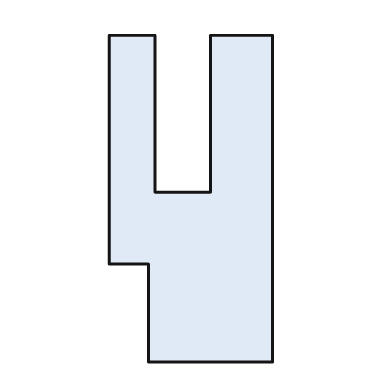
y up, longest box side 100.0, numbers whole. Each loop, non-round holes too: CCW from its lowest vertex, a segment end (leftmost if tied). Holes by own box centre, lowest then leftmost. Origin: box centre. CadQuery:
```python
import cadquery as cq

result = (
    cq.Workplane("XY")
    .moveTo(-13.0, -50.0)
    .lineTo(25.0, -50.0)
    .lineTo(25.0, 50.0)
    .lineTo(6.0, 50.0)
    .lineTo(6.0, 2.0)
    .lineTo(-11.0, 2.0)
    .lineTo(-11.0, 50.0)
    .lineTo(-25.0, 50.0)
    .lineTo(-25.0, -20.0)
    .lineTo(-13.0, -20.0)
    .close()
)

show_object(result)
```